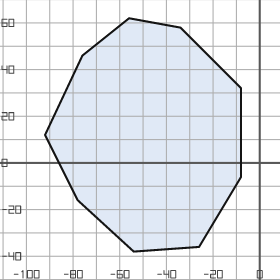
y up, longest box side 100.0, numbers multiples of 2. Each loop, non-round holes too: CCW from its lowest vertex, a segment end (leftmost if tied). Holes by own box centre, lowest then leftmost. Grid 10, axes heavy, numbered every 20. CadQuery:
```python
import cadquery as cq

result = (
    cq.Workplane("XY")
    .moveTo(-54.0, -38.0)
    .lineTo(-26.0, -36.0)
    .lineTo(-8.0, -6.0)
    .lineTo(-8.0, 32.0)
    .lineTo(-34.0, 58.0)
    .lineTo(-56.0, 62.0)
    .lineTo(-76.0, 46.0)
    .lineTo(-92.0, 12.0)
    .lineTo(-78.0, -16.0)
    .close()
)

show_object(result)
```